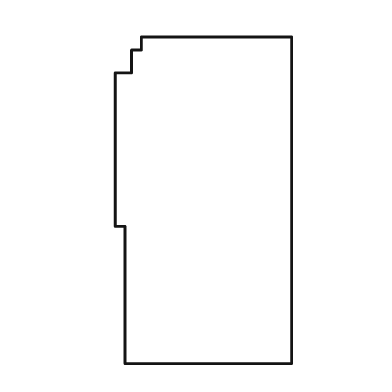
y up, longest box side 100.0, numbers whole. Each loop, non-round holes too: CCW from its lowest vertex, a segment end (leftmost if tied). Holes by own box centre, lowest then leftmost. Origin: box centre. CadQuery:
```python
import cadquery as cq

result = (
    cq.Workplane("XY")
    .moveTo(-24.0, -50.0)
    .lineTo(27.0, -50.0)
    .lineTo(27.0, 50.0)
    .lineTo(-19.0, 50.0)
    .lineTo(-19.0, 46.0)
    .lineTo(-22.0, 46.0)
    .lineTo(-22.0, 39.0)
    .lineTo(-27.0, 39.0)
    .lineTo(-27.0, -8.0)
    .lineTo(-24.0, -8.0)
    .close()
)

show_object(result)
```